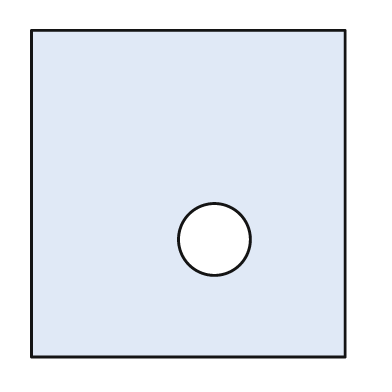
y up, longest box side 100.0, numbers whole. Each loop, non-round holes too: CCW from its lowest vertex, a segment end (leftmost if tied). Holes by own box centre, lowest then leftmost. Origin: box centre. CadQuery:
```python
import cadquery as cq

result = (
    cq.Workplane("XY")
    .moveTo(-48.0, -50.0)
    .lineTo(48.0, -50.0)
    .lineTo(48.0, 50.0)
    .lineTo(-48.0, 50.0)
    .close()
    .moveTo(8.0, -14.0)
    .circle(11.0)
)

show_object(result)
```